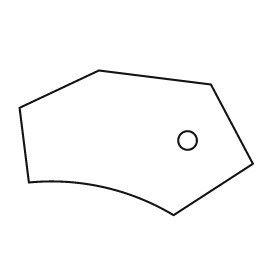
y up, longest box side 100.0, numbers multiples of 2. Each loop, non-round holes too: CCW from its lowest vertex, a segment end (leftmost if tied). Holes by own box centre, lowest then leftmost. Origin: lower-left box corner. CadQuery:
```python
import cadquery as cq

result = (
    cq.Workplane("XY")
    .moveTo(66.0, 0.0)
    .lineTo(100.0, 22.0)
    .lineTo(82.0, 56.0)
    .lineTo(34.0, 62.0)
    .lineTo(0.0, 46.0)
    .lineTo(4.0, 14.0)
    .threePointArc((36.0, 12.0), (66.0, 0.0))
    .close()
    .moveTo(72.0, 32.0)
    .circle(4.0)
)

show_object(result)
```